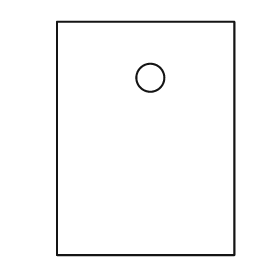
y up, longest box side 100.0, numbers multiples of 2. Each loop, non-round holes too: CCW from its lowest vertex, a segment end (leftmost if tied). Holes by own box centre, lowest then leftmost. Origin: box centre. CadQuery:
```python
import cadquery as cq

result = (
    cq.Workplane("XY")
    .moveTo(-38.0, -50.0)
    .lineTo(38.0, -50.0)
    .lineTo(38.0, 50.0)
    .lineTo(-38.0, 50.0)
    .close()
    .moveTo(2.0, 26.0)
    .circle(6.0)
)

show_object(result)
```